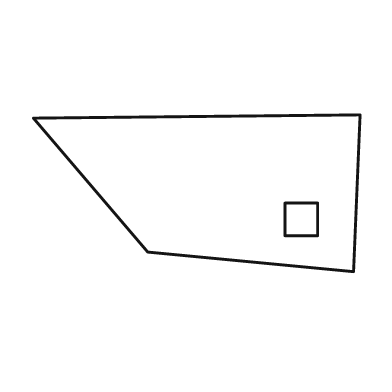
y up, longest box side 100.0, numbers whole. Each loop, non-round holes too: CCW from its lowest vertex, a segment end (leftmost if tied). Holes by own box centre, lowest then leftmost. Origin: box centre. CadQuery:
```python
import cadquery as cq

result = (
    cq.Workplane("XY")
    .moveTo(48.0, -24.0)
    .lineTo(50.0, 24.0)
    .lineTo(-50.0, 23.0)
    .lineTo(-15.0, -18.0)
    .close()
    .moveTo(27.0, -13.0)
    .lineTo(37.0, -13.0)
    .lineTo(37.0, -3.0)
    .lineTo(27.0, -3.0)
    .close()
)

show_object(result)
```